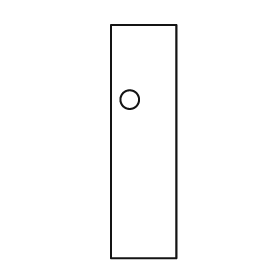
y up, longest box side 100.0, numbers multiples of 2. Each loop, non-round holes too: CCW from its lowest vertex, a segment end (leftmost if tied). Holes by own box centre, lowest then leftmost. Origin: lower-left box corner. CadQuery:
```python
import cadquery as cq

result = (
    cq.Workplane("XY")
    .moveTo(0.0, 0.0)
    .lineTo(28.0, 0.0)
    .lineTo(28.0, 100.0)
    .lineTo(0.0, 100.0)
    .close()
    .moveTo(8.0, 68.0)
    .circle(4.0)
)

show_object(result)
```